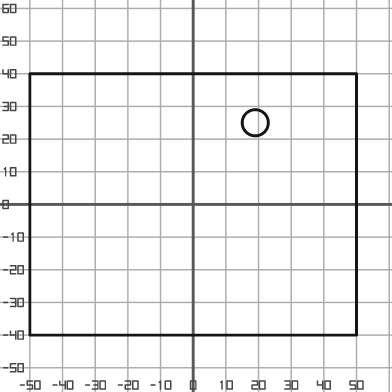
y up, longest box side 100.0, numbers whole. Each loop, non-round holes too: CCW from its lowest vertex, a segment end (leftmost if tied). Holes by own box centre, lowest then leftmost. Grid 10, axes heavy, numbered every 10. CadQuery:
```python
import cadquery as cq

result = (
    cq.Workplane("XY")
    .moveTo(-50.0, -40.0)
    .lineTo(50.0, -40.0)
    .lineTo(50.0, 40.0)
    .lineTo(-50.0, 40.0)
    .close()
    .moveTo(19.0, 25.0)
    .circle(4.0)
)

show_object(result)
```